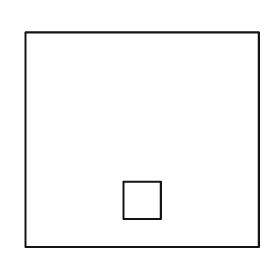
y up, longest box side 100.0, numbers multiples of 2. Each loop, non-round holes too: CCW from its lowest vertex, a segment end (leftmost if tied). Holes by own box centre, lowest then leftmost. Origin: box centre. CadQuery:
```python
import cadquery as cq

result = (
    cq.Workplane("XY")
    .moveTo(-50.0, -46.0)
    .lineTo(50.0, -46.0)
    .lineTo(50.0, 46.0)
    .lineTo(-50.0, 46.0)
    .close()
    .moveTo(-8.0, -34.0)
    .lineTo(8.0, -34.0)
    .lineTo(8.0, -18.0)
    .lineTo(-8.0, -18.0)
    .close()
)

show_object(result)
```